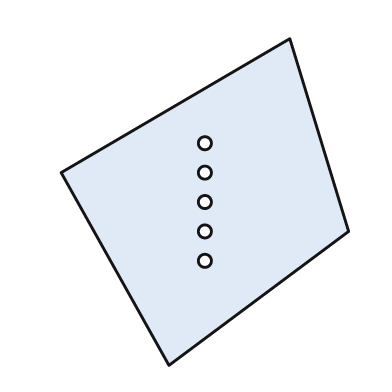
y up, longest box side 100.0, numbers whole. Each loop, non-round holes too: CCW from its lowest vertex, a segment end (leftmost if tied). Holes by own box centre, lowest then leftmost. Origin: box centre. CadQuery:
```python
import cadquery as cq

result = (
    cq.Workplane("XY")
    .moveTo(-11.0, -50.0)
    .lineTo(44.0, -9.0)
    .lineTo(26.0, 50.0)
    .lineTo(-44.0, 9.0)
    .close()
    .moveTo(0.0, -18.0)
    .circle(2.0)
    .moveTo(0.0, -9.0)
    .circle(2.0)
    .moveTo(0.0, 0.0)
    .circle(2.0)
    .moveTo(0.0, 9.0)
    .circle(2.0)
    .moveTo(0.0, 18.0)
    .circle(2.0)
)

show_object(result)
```